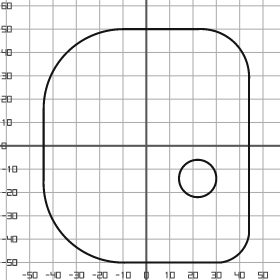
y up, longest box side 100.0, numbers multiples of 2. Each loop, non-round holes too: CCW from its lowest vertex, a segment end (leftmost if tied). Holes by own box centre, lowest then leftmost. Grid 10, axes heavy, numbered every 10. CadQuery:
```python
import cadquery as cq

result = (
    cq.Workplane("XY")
    .moveTo(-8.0, -50.0)
    .lineTo(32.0, -50.0)
    .threePointArc((40.0, -46.0), (44.0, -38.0))
    .lineTo(44.0, 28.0)
    .threePointArc((38.0, 44.0), (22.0, 50.0))
    .lineTo(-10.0, 50.0)
    .threePointArc((-34.0, 40.0), (-44.0, 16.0))
    .lineTo(-44.0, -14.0)
    .threePointArc((-34.0, -40.0), (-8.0, -50.0))
    .close()
    .moveTo(22.0, -14.0)
    .circle(8.0)
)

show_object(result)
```